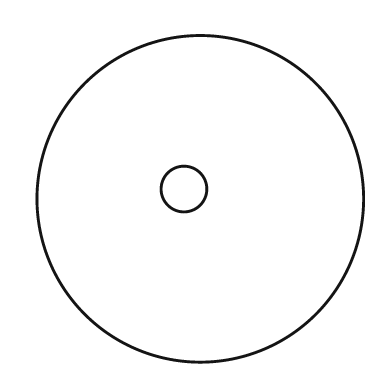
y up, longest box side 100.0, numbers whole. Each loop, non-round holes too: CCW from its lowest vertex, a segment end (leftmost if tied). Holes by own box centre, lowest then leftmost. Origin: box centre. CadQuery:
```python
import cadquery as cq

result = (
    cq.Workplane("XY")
    .moveTo(0.0, 0.0)
    .circle(50.0)
    .moveTo(-5.0, 3.0)
    .circle(7.0)
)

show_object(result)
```